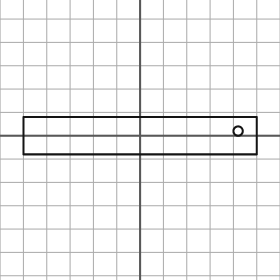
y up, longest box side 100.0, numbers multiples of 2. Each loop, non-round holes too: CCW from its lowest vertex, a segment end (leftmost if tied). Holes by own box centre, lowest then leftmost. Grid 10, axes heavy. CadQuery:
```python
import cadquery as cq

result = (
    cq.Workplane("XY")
    .moveTo(-50.0, -8.0)
    .lineTo(50.0, -8.0)
    .lineTo(50.0, 8.0)
    .lineTo(-50.0, 8.0)
    .close()
    .moveTo(42.0, 2.0)
    .circle(2.0)
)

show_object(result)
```